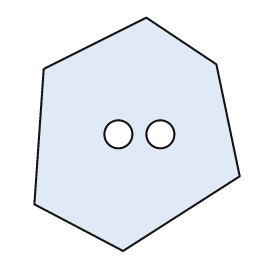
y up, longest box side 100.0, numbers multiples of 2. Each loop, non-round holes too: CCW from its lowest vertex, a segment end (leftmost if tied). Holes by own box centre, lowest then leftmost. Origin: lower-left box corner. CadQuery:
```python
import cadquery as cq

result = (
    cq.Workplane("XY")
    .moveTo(38.0, 0.0)
    .lineTo(88.0, 32.0)
    .lineTo(78.0, 80.0)
    .lineTo(48.0, 100.0)
    .lineTo(4.0, 78.0)
    .lineTo(0.0, 20.0)
    .close()
    .moveTo(36.0, 50.0)
    .circle(6.0)
    .moveTo(54.0, 50.0)
    .circle(6.0)
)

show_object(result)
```